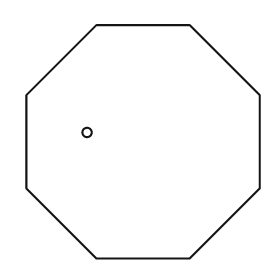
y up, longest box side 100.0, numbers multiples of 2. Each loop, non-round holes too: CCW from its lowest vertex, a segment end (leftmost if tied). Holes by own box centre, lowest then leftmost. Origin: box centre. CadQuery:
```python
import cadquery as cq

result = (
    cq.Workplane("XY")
    .moveTo(-20.0, -50.0)
    .lineTo(20.0, -50.0)
    .lineTo(50.0, -20.0)
    .lineTo(50.0, 20.0)
    .lineTo(20.0, 50.0)
    .lineTo(-20.0, 50.0)
    .lineTo(-50.0, 20.0)
    .lineTo(-50.0, -20.0)
    .close()
    .moveTo(-24.0, 4.0)
    .circle(2.0)
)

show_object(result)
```